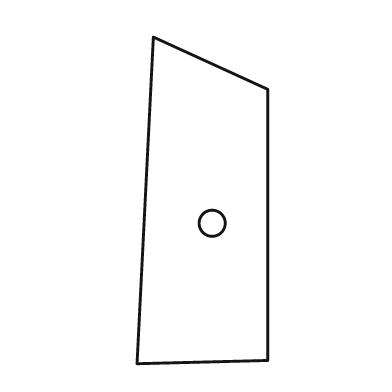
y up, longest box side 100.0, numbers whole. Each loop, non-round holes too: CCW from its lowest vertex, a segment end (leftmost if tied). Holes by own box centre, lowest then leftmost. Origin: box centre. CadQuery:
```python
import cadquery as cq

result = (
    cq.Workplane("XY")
    .moveTo(-20.0, -50.0)
    .lineTo(20.0, -49.0)
    .lineTo(20.0, 34.0)
    .lineTo(-15.0, 50.0)
    .close()
    .moveTo(3.0, -7.0)
    .circle(4.0)
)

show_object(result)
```